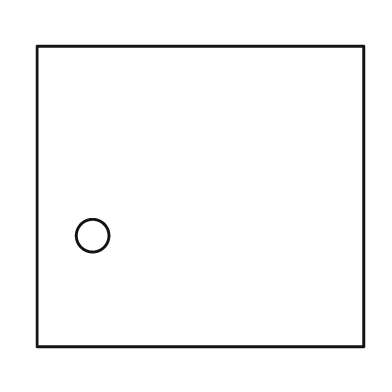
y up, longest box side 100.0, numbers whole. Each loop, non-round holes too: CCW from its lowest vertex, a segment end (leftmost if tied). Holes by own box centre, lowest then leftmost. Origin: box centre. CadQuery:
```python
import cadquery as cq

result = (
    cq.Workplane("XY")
    .moveTo(-50.0, -46.0)
    .lineTo(50.0, -46.0)
    .lineTo(50.0, 46.0)
    .lineTo(-50.0, 46.0)
    .close()
    .moveTo(-33.0, -12.0)
    .circle(5.0)
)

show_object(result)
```